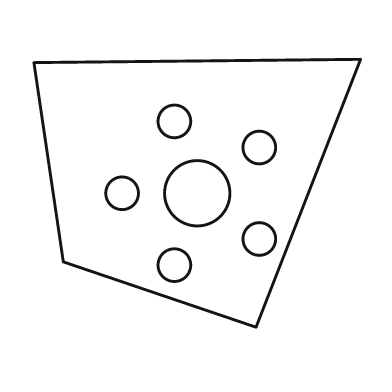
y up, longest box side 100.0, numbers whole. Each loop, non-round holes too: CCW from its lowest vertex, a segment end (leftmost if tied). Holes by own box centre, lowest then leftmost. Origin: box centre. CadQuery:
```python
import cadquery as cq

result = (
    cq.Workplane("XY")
    .moveTo(18.0, -41.0)
    .lineTo(50.0, 41.0)
    .lineTo(-50.0, 40.0)
    .lineTo(-41.0, -21.0)
    .close()
    .moveTo(-7.0, -22.0)
    .circle(5.0)
    .moveTo(19.0, -14.0)
    .circle(5.0)
    .moveTo(-23.0, 0.0)
    .circle(5.0)
    .moveTo(0.0, 0.0)
    .circle(10.0)
    .moveTo(19.0, 14.0)
    .circle(5.0)
    .moveTo(-7.0, 22.0)
    .circle(5.0)
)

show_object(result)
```